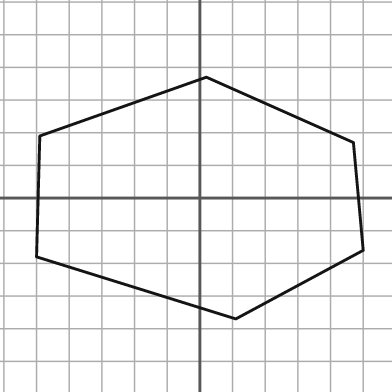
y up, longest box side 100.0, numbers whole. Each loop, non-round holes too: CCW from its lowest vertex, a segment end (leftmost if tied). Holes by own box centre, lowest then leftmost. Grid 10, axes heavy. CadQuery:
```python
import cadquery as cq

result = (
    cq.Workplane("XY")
    .moveTo(11.0, -37.0)
    .lineTo(50.0, -16.0)
    .lineTo(47.0, 17.0)
    .lineTo(2.0, 37.0)
    .lineTo(-49.0, 19.0)
    .lineTo(-50.0, -18.0)
    .close()
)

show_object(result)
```